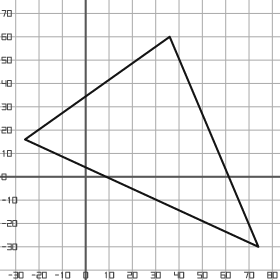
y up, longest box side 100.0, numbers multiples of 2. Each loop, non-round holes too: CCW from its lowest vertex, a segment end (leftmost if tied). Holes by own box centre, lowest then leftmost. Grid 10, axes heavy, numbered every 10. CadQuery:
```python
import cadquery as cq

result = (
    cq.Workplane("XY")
    .moveTo(74.0, -30.0)
    .lineTo(36.0, 60.0)
    .lineTo(-26.0, 16.0)
    .close()
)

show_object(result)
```